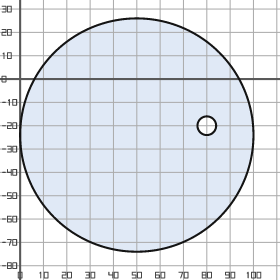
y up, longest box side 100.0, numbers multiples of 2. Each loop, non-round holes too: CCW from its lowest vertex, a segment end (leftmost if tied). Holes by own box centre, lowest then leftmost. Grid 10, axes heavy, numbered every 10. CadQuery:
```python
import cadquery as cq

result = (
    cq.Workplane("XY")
    .moveTo(50.0, -24.0)
    .circle(50.0)
    .moveTo(80.0, -20.0)
    .circle(4.0)
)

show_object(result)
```